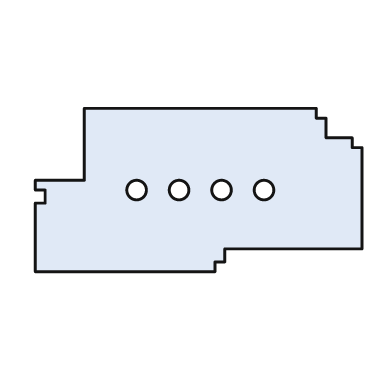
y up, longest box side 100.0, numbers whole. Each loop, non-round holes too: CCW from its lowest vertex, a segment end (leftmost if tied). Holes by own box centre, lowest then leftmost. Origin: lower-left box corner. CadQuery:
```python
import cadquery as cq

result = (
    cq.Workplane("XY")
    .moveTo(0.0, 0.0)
    .lineTo(55.0, 0.0)
    .lineTo(55.0, 3.0)
    .lineTo(58.0, 3.0)
    .lineTo(58.0, 7.0)
    .lineTo(100.0, 7.0)
    .lineTo(100.0, 38.0)
    .lineTo(97.0, 38.0)
    .lineTo(97.0, 41.0)
    .lineTo(89.0, 41.0)
    .lineTo(89.0, 47.0)
    .lineTo(86.0, 47.0)
    .lineTo(86.0, 50.0)
    .lineTo(15.0, 50.0)
    .lineTo(15.0, 28.0)
    .lineTo(0.0, 28.0)
    .lineTo(0.0, 25.0)
    .lineTo(3.0, 25.0)
    .lineTo(3.0, 21.0)
    .lineTo(0.0, 21.0)
    .close()
    .moveTo(31.0, 25.0)
    .circle(3.0)
    .moveTo(44.0, 25.0)
    .circle(3.0)
    .moveTo(57.0, 25.0)
    .circle(3.0)
    .moveTo(70.0, 25.0)
    .circle(3.0)
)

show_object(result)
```